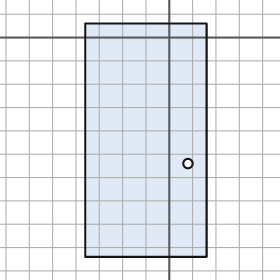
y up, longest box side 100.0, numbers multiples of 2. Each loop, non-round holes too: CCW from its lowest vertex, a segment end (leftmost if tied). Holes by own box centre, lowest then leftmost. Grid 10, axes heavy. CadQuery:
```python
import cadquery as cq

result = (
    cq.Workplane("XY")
    .moveTo(-36.0, -94.0)
    .lineTo(16.0, -94.0)
    .lineTo(16.0, 6.0)
    .lineTo(-36.0, 6.0)
    .close()
    .moveTo(8.0, -54.0)
    .circle(2.0)
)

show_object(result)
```